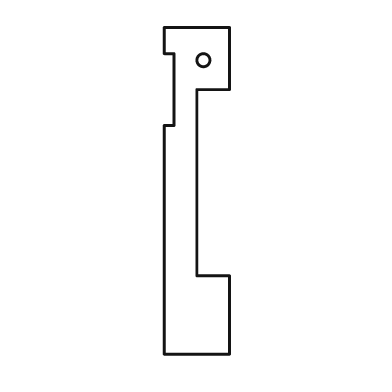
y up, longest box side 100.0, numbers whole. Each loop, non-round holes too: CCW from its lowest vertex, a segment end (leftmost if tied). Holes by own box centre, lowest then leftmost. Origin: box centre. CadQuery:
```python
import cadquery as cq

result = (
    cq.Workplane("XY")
    .moveTo(-10.0, -50.0)
    .lineTo(10.0, -50.0)
    .lineTo(10.0, -26.0)
    .lineTo(0.0, -26.0)
    .lineTo(0.0, 31.0)
    .lineTo(10.0, 31.0)
    .lineTo(10.0, 50.0)
    .lineTo(-10.0, 50.0)
    .lineTo(-10.0, 42.0)
    .lineTo(-7.0, 42.0)
    .lineTo(-7.0, 20.0)
    .lineTo(-10.0, 20.0)
    .close()
    .moveTo(2.0, 40.0)
    .circle(2.0)
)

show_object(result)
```